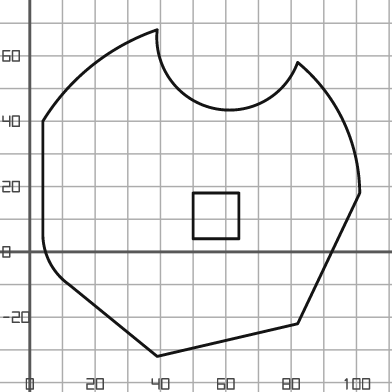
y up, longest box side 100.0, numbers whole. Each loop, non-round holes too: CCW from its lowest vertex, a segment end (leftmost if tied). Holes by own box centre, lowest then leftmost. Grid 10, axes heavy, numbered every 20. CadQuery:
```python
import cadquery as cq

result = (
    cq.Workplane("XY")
    .moveTo(39.0, -32.0)
    .lineTo(82.0, -22.0)
    .lineTo(101.0, 18.0)
    .threePointArc((96.0, 40.0), (82.0, 58.0))
    .threePointArc((56.0, 44.0), (39.0, 68.0))
    .threePointArc((19.0, 57.0), (4.0, 40.0))
    .lineTo(4.0, 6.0)
    .threePointArc((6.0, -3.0), (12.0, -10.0))
    .close()
    .moveTo(50.0, 4.0)
    .lineTo(64.0, 4.0)
    .lineTo(64.0, 18.0)
    .lineTo(50.0, 18.0)
    .close()
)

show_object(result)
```